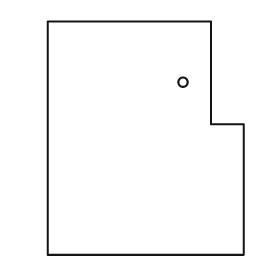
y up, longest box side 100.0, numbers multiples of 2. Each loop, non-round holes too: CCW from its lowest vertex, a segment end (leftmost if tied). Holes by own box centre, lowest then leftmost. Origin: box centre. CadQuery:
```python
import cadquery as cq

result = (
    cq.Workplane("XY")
    .moveTo(-42.0, -50.0)
    .lineTo(42.0, -50.0)
    .lineTo(42.0, 6.0)
    .lineTo(28.0, 6.0)
    .lineTo(28.0, 50.0)
    .lineTo(-42.0, 50.0)
    .close()
    .moveTo(16.0, 24.0)
    .circle(2.0)
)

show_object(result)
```